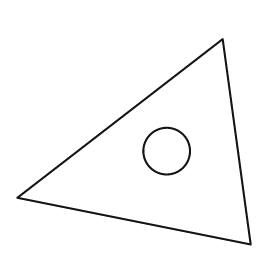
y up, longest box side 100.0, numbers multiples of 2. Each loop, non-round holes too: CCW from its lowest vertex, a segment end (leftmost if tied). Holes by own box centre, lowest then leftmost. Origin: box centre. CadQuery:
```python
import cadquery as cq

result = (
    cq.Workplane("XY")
    .moveTo(50.0, -44.0)
    .lineTo(38.0, 44.0)
    .lineTo(-50.0, -24.0)
    .close()
    .moveTo(14.0, -4.0)
    .circle(10.0)
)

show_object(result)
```